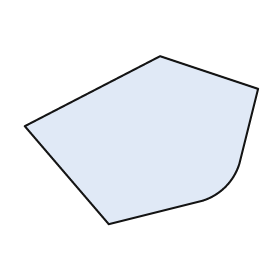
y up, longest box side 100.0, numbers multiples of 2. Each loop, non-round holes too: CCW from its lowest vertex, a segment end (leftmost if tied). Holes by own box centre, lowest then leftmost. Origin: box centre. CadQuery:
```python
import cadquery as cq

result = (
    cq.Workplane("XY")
    .moveTo(-14.0, -36.0)
    .lineTo(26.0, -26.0)
    .threePointArc((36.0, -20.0), (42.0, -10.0))
    .lineTo(50.0, 22.0)
    .lineTo(8.0, 36.0)
    .lineTo(-50.0, 6.0)
    .close()
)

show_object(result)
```